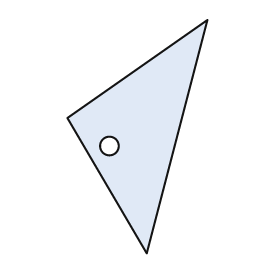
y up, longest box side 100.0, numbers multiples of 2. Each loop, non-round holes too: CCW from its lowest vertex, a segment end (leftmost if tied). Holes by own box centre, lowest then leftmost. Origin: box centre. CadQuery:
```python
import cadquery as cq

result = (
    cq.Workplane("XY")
    .moveTo(4.0, -50.0)
    .lineTo(30.0, 50.0)
    .lineTo(-30.0, 8.0)
    .close()
    .moveTo(-12.0, -4.0)
    .circle(4.0)
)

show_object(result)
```